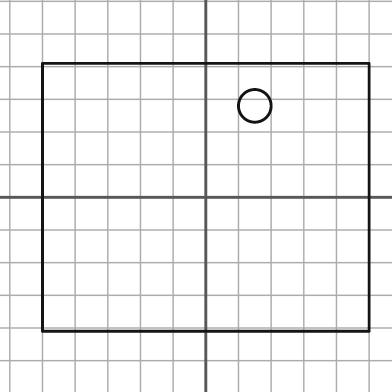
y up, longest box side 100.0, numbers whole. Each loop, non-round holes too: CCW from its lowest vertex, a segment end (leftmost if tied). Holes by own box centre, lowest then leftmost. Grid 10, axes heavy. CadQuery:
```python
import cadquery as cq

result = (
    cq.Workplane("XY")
    .moveTo(-50.0, -41.0)
    .lineTo(50.0, -41.0)
    .lineTo(50.0, 41.0)
    .lineTo(-50.0, 41.0)
    .close()
    .moveTo(15.0, 28.0)
    .circle(5.0)
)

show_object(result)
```